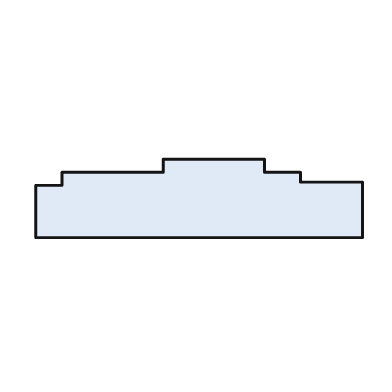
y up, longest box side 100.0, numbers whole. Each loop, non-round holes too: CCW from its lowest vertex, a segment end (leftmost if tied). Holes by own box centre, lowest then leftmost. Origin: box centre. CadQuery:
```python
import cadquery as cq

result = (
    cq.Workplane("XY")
    .moveTo(-50.0, -12.0)
    .lineTo(50.0, -12.0)
    .lineTo(50.0, 5.0)
    .lineTo(31.0, 5.0)
    .lineTo(31.0, 8.0)
    .lineTo(20.0, 8.0)
    .lineTo(20.0, 12.0)
    .lineTo(-11.0, 12.0)
    .lineTo(-11.0, 8.0)
    .lineTo(-42.0, 8.0)
    .lineTo(-42.0, 4.0)
    .lineTo(-50.0, 4.0)
    .close()
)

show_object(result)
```